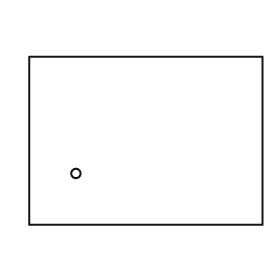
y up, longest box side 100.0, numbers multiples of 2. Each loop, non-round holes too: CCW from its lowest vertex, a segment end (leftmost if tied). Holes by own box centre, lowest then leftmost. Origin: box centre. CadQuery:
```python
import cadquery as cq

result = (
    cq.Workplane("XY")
    .moveTo(-50.0, -36.0)
    .lineTo(50.0, -36.0)
    .lineTo(50.0, 36.0)
    .lineTo(-50.0, 36.0)
    .close()
    .moveTo(-30.0, -14.0)
    .circle(2.0)
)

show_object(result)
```